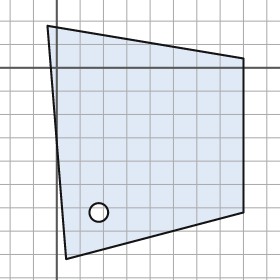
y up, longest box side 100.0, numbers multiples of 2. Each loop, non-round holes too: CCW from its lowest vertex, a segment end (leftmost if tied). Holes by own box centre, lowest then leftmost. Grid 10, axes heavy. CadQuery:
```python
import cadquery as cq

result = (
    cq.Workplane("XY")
    .moveTo(4.0, -82.0)
    .lineTo(80.0, -62.0)
    .lineTo(80.0, 4.0)
    .lineTo(-4.0, 18.0)
    .close()
    .moveTo(18.0, -62.0)
    .circle(4.0)
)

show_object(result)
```